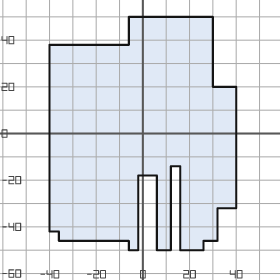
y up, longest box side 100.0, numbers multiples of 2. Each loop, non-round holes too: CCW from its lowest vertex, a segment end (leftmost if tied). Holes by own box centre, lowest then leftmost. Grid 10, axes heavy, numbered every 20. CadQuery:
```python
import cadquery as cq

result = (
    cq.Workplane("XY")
    .moveTo(-6.0, -50.0)
    .lineTo(-2.0, -50.0)
    .lineTo(-2.0, -18.0)
    .lineTo(6.0, -18.0)
    .lineTo(6.0, -50.0)
    .lineTo(12.0, -50.0)
    .lineTo(12.0, -14.0)
    .lineTo(16.0, -14.0)
    .lineTo(16.0, -50.0)
    .lineTo(26.0, -50.0)
    .lineTo(26.0, -46.0)
    .lineTo(32.0, -46.0)
    .lineTo(32.0, -32.0)
    .lineTo(40.0, -32.0)
    .lineTo(40.0, 20.0)
    .lineTo(30.0, 20.0)
    .lineTo(30.0, 50.0)
    .lineTo(-6.0, 50.0)
    .lineTo(-6.0, 38.0)
    .lineTo(-40.0, 38.0)
    .lineTo(-40.0, -42.0)
    .lineTo(-36.0, -42.0)
    .lineTo(-36.0, -46.0)
    .lineTo(-6.0, -46.0)
    .close()
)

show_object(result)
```